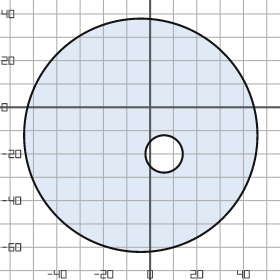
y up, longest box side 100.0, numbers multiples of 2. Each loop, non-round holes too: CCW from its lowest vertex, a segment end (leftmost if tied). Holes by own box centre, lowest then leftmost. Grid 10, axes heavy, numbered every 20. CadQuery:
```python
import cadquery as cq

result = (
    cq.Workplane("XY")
    .moveTo(-4.0, -12.0)
    .circle(50.0)
    .moveTo(6.0, -20.0)
    .circle(8.0)
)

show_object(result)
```